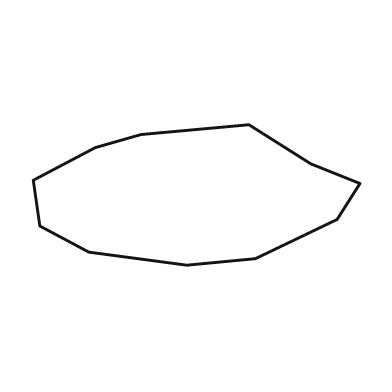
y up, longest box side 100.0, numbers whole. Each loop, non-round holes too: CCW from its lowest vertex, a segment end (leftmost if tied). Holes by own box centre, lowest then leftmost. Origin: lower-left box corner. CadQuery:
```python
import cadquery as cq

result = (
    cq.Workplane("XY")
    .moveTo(47.0, 0.0)
    .lineTo(68.0, 2.0)
    .lineTo(93.0, 14.0)
    .lineTo(100.0, 25.0)
    .lineTo(85.0, 31.0)
    .lineTo(66.0, 43.0)
    .lineTo(33.0, 40.0)
    .lineTo(19.0, 36.0)
    .lineTo(0.0, 26.0)
    .lineTo(2.0, 12.0)
    .lineTo(17.0, 4.0)
    .close()
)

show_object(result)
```